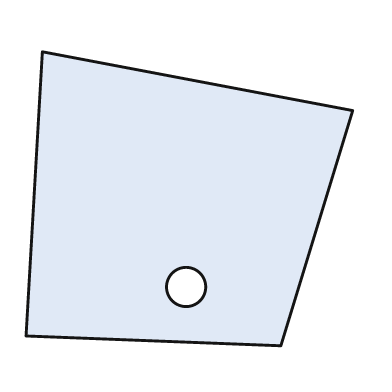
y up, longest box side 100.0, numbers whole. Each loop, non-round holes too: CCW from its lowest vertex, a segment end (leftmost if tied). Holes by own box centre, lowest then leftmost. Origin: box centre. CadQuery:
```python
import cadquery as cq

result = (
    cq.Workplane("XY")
    .moveTo(28.0, -45.0)
    .lineTo(50.0, 27.0)
    .lineTo(-45.0, 45.0)
    .lineTo(-50.0, -42.0)
    .close()
    .moveTo(-1.0, -27.0)
    .circle(6.0)
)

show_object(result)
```